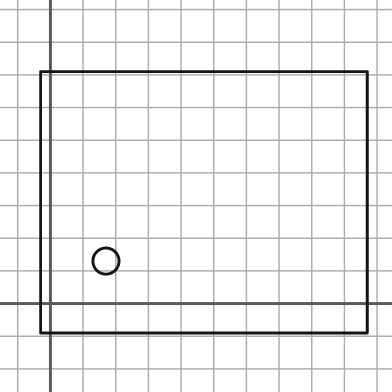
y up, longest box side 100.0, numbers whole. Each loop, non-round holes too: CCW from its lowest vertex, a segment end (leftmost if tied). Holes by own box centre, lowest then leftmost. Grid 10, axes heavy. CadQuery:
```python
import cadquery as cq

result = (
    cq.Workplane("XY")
    .moveTo(-3.0, -9.0)
    .lineTo(97.0, -9.0)
    .lineTo(97.0, 71.0)
    .lineTo(-3.0, 71.0)
    .close()
    .moveTo(17.0, 13.0)
    .circle(4.0)
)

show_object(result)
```